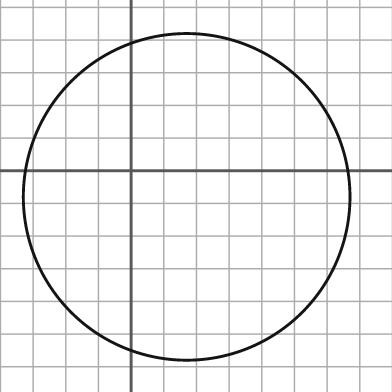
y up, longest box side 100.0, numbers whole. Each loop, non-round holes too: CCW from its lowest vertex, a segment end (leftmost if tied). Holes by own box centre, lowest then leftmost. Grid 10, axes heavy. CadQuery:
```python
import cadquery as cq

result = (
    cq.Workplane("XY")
    .moveTo(17.0, -8.0)
    .circle(50.0)
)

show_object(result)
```